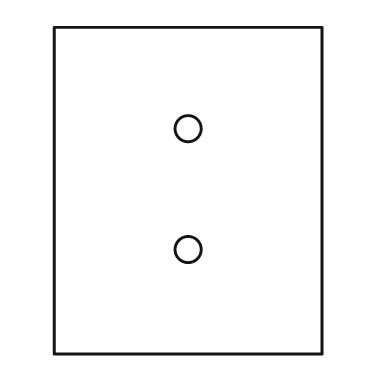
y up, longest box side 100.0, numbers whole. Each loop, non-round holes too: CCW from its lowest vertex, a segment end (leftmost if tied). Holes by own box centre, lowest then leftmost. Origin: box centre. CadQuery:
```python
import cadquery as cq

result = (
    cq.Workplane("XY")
    .moveTo(-41.0, -50.0)
    .lineTo(41.0, -50.0)
    .lineTo(41.0, 50.0)
    .lineTo(-41.0, 50.0)
    .close()
    .moveTo(0.0, -18.0)
    .circle(4.0)
    .moveTo(0.0, 19.0)
    .circle(4.0)
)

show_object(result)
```